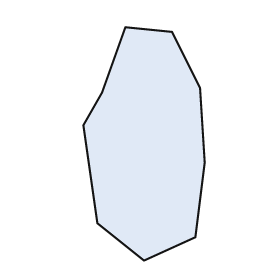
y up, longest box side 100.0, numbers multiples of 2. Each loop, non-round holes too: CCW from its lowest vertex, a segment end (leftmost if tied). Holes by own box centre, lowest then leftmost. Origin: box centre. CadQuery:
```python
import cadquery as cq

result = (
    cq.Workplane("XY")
    .moveTo(0.0, -50.0)
    .lineTo(22.0, -40.0)
    .lineTo(26.0, -8.0)
    .lineTo(24.0, 24.0)
    .lineTo(12.0, 48.0)
    .lineTo(-8.0, 50.0)
    .lineTo(-18.0, 22.0)
    .lineTo(-26.0, 8.0)
    .lineTo(-20.0, -34.0)
    .close()
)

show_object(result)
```